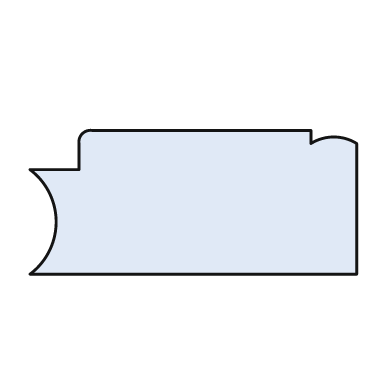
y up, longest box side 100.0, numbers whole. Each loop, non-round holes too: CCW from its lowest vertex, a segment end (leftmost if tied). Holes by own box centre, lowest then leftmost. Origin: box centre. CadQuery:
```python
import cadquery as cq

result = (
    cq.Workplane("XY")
    .moveTo(-50.0, -22.0)
    .lineTo(50.0, -22.0)
    .lineTo(50.0, 18.0)
    .threePointArc((43.0, 20.0), (36.0, 18.0))
    .lineTo(36.0, 22.0)
    .lineTo(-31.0, 22.0)
    .threePointArc((-34.0, 21.0), (-35.0, 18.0))
    .lineTo(-35.0, 10.0)
    .lineTo(-50.0, 10.0)
    .threePointArc((-42.0, -6.0), (-50.0, -22.0))
    .close()
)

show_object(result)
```